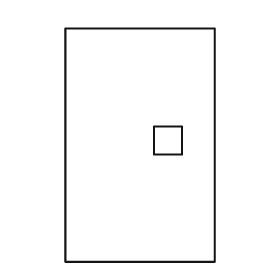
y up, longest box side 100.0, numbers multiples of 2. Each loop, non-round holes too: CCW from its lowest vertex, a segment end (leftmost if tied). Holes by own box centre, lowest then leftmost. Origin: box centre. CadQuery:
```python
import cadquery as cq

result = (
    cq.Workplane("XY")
    .moveTo(-32.0, -50.0)
    .lineTo(32.0, -50.0)
    .lineTo(32.0, 50.0)
    .lineTo(-32.0, 50.0)
    .close()
    .moveTo(6.0, -4.0)
    .lineTo(18.0, -4.0)
    .lineTo(18.0, 8.0)
    .lineTo(6.0, 8.0)
    .close()
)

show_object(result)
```